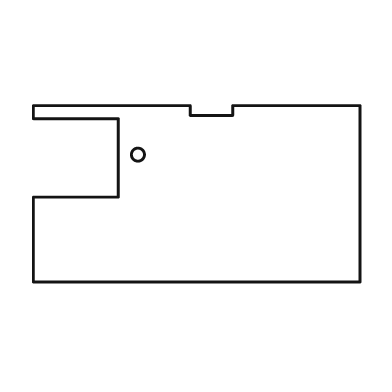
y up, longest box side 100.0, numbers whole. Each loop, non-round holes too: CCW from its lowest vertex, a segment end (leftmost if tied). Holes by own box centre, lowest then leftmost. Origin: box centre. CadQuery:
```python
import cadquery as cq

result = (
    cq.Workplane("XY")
    .moveTo(-50.0, -27.0)
    .lineTo(50.0, -27.0)
    .lineTo(50.0, 27.0)
    .lineTo(11.0, 27.0)
    .lineTo(11.0, 24.0)
    .lineTo(-2.0, 24.0)
    .lineTo(-2.0, 27.0)
    .lineTo(-50.0, 27.0)
    .lineTo(-50.0, 23.0)
    .lineTo(-24.0, 23.0)
    .lineTo(-24.0, -1.0)
    .lineTo(-50.0, -1.0)
    .close()
    .moveTo(-18.0, 12.0)
    .circle(2.0)
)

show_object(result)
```